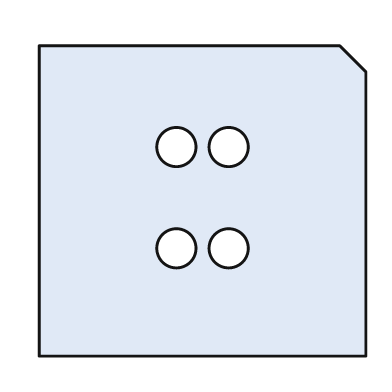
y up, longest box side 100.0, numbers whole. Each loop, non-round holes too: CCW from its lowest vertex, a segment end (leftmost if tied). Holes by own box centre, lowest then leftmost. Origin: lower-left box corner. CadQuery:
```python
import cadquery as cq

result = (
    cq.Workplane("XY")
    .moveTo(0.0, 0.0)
    .lineTo(100.0, 0.0)
    .lineTo(100.0, 87.0)
    .lineTo(92.0, 95.0)
    .lineTo(0.0, 95.0)
    .close()
    .moveTo(42.0, 33.0)
    .circle(6.0)
    .moveTo(58.0, 33.0)
    .circle(6.0)
    .moveTo(42.0, 64.0)
    .circle(6.0)
    .moveTo(58.0, 64.0)
    .circle(6.0)
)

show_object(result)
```